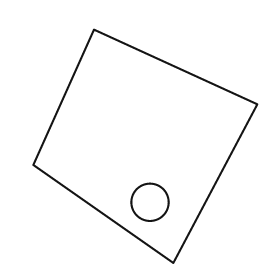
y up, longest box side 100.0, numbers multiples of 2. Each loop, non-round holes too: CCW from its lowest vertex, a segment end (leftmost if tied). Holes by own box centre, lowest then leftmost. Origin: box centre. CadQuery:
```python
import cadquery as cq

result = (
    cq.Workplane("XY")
    .moveTo(12.0, -50.0)
    .lineTo(48.0, 18.0)
    .lineTo(-22.0, 50.0)
    .lineTo(-48.0, -8.0)
    .close()
    .moveTo(2.0, -24.0)
    .circle(8.0)
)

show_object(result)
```